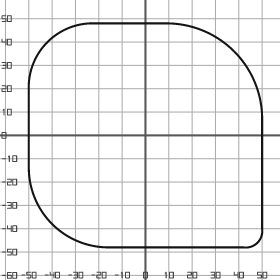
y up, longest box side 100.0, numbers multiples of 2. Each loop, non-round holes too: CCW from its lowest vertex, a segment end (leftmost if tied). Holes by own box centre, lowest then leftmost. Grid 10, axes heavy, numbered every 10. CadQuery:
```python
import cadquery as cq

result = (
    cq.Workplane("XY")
    .moveTo(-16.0, -48.0)
    .lineTo(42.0, -48.0)
    .threePointArc((48.0, -46.0), (50.0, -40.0))
    .lineTo(50.0, 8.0)
    .threePointArc((38.0, 36.0), (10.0, 48.0))
    .lineTo(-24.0, 48.0)
    .threePointArc((-42.0, 40.0), (-50.0, 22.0))
    .lineTo(-50.0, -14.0)
    .threePointArc((-40.0, -38.0), (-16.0, -48.0))
    .close()
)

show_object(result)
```